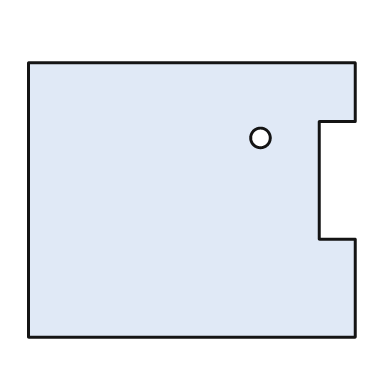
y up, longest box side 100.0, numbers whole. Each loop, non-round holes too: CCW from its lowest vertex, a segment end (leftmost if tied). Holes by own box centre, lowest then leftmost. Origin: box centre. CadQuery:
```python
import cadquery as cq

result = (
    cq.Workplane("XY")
    .moveTo(-50.0, -42.0)
    .lineTo(50.0, -42.0)
    .lineTo(50.0, -12.0)
    .lineTo(39.0, -12.0)
    .lineTo(39.0, 24.0)
    .lineTo(50.0, 24.0)
    .lineTo(50.0, 42.0)
    .lineTo(-50.0, 42.0)
    .close()
    .moveTo(21.0, 19.0)
    .circle(3.0)
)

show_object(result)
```